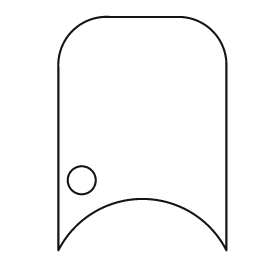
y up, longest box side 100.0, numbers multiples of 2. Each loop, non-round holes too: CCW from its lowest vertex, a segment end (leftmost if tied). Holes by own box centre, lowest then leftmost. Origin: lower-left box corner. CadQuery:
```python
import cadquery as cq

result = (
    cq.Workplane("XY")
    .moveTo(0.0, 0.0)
    .threePointArc((36.0, 22.0), (72.0, 0.0))
    .lineTo(72.0, 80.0)
    .threePointArc((66.0, 94.0), (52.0, 100.0))
    .lineTo(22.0, 100.0)
    .threePointArc((6.0, 94.0), (0.0, 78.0))
    .close()
    .moveTo(10.0, 30.0)
    .circle(6.0)
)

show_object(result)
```